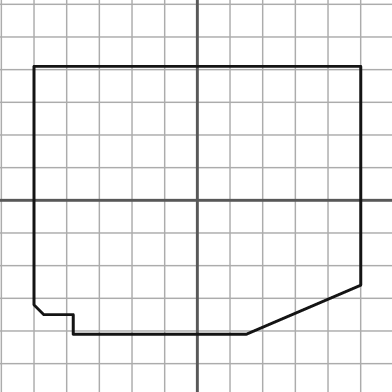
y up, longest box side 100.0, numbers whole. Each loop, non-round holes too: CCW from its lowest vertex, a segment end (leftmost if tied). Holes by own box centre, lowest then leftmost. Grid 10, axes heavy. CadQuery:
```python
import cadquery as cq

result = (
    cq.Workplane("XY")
    .moveTo(-38.0, -41.0)
    .lineTo(15.0, -41.0)
    .lineTo(50.0, -26.0)
    .lineTo(50.0, 41.0)
    .lineTo(-50.0, 41.0)
    .lineTo(-50.0, -32.0)
    .lineTo(-47.0, -35.0)
    .lineTo(-38.0, -35.0)
    .close()
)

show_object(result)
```